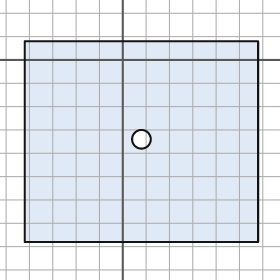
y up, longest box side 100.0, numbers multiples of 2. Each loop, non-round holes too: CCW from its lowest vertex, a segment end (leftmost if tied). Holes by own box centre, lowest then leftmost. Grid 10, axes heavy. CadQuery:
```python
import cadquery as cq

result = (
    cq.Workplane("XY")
    .moveTo(-42.0, -78.0)
    .lineTo(58.0, -78.0)
    .lineTo(58.0, 8.0)
    .lineTo(-42.0, 8.0)
    .close()
    .moveTo(8.0, -34.0)
    .circle(4.0)
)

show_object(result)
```